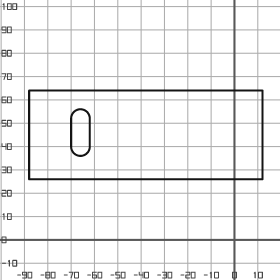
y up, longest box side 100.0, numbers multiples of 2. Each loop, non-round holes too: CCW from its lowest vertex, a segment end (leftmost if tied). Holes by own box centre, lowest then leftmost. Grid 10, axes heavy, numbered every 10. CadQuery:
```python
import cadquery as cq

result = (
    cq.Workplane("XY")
    .moveTo(-88.0, 26.0)
    .lineTo(12.0, 26.0)
    .lineTo(12.0, 64.0)
    .lineTo(-88.0, 64.0)
    .close()
    .moveTo(-70.0, 40.0)
    .threePointArc((-66.0, 36.0), (-62.0, 40.0))
    .lineTo(-62.0, 52.0)
    .threePointArc((-66.0, 56.0), (-70.0, 52.0))
    .close()
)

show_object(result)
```